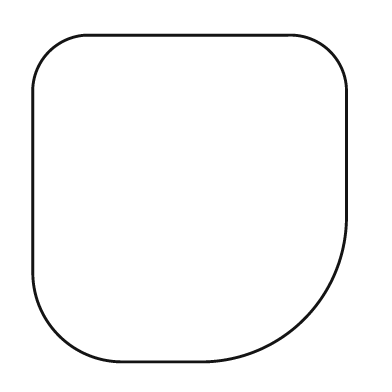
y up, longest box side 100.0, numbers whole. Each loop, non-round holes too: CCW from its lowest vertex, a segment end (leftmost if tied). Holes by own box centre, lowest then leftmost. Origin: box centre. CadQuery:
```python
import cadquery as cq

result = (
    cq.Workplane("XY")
    .moveTo(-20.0, -50.0)
    .lineTo(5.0, -50.0)
    .threePointArc((35.0, -37.0), (48.0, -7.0))
    .lineTo(48.0, 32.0)
    .threePointArc((43.0, 45.0), (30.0, 50.0))
    .lineTo(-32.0, 50.0)
    .threePointArc((-43.0, 45.0), (-48.0, 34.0))
    .lineTo(-48.0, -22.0)
    .threePointArc((-40.0, -42.0), (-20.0, -50.0))
    .close()
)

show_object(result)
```